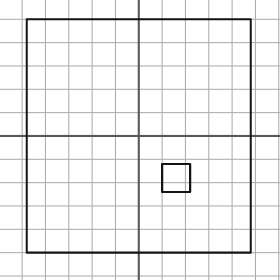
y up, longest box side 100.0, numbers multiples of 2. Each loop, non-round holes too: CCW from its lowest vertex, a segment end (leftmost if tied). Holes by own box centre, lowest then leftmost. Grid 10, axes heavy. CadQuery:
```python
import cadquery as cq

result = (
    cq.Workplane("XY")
    .moveTo(-48.0, -50.0)
    .lineTo(48.0, -50.0)
    .lineTo(48.0, 50.0)
    .lineTo(-48.0, 50.0)
    .close()
    .moveTo(10.0, -24.0)
    .lineTo(22.0, -24.0)
    .lineTo(22.0, -12.0)
    .lineTo(10.0, -12.0)
    .close()
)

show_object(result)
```